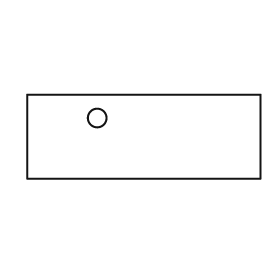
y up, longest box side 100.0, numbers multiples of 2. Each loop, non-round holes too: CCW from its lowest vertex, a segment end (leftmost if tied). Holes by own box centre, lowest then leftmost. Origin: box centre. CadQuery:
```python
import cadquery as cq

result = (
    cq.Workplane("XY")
    .moveTo(-50.0, -18.0)
    .lineTo(50.0, -18.0)
    .lineTo(50.0, 18.0)
    .lineTo(-50.0, 18.0)
    .close()
    .moveTo(-20.0, 8.0)
    .circle(4.0)
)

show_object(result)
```